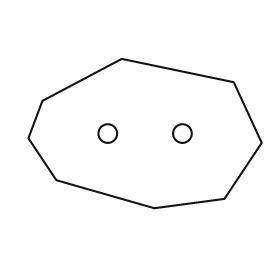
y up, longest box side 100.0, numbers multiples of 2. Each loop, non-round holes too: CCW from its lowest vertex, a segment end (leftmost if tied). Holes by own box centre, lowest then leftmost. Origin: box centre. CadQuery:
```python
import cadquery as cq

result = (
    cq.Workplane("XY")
    .moveTo(4.0, -32.0)
    .lineTo(34.0, -28.0)
    .lineTo(50.0, -4.0)
    .lineTo(38.0, 22.0)
    .lineTo(-10.0, 32.0)
    .lineTo(-44.0, 14.0)
    .lineTo(-50.0, -2.0)
    .lineTo(-38.0, -20.0)
    .close()
    .moveTo(-16.0, 0.0)
    .circle(4.0)
    .moveTo(16.0, 0.0)
    .circle(4.0)
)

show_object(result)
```